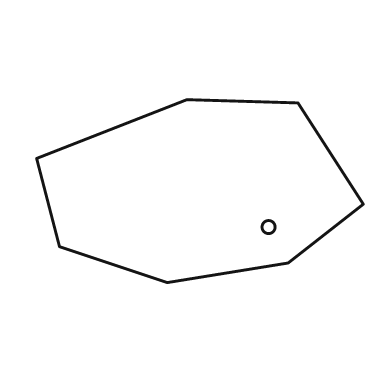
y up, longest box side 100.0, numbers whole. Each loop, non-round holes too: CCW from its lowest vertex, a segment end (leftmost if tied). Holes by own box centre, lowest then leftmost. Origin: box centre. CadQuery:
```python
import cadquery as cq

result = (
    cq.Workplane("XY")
    .moveTo(-10.0, -28.0)
    .lineTo(27.0, -22.0)
    .lineTo(50.0, -4.0)
    .lineTo(30.0, 27.0)
    .lineTo(-4.0, 28.0)
    .lineTo(-50.0, 10.0)
    .lineTo(-43.0, -17.0)
    .close()
    .moveTo(21.0, -11.0)
    .circle(2.0)
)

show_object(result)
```